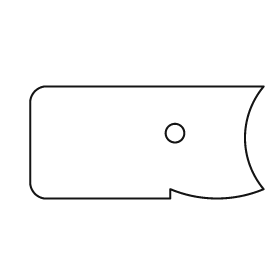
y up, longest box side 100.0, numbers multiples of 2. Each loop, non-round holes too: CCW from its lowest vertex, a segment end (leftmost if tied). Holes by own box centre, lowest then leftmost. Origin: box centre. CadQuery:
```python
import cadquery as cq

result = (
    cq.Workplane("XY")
    .moveTo(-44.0, -24.0)
    .lineTo(10.0, -24.0)
    .lineTo(10.0, -20.0)
    .threePointArc((30.0, -24.0), (50.0, -20.0))
    .threePointArc((42.0, 2.0), (50.0, 24.0))
    .lineTo(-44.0, 24.0)
    .threePointArc((-48.0, 22.0), (-50.0, 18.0))
    .lineTo(-50.0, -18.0)
    .threePointArc((-48.0, -22.0), (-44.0, -24.0))
    .close()
    .moveTo(12.0, 4.0)
    .circle(4.0)
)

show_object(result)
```